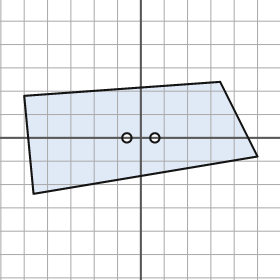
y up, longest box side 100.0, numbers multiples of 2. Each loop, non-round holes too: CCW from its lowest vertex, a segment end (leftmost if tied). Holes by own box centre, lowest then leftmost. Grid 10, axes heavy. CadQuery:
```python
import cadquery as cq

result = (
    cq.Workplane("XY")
    .moveTo(-46.0, -24.0)
    .lineTo(50.0, -8.0)
    .lineTo(34.0, 24.0)
    .lineTo(-50.0, 18.0)
    .close()
    .moveTo(-6.0, 0.0)
    .circle(2.0)
    .moveTo(6.0, 0.0)
    .circle(2.0)
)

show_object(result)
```